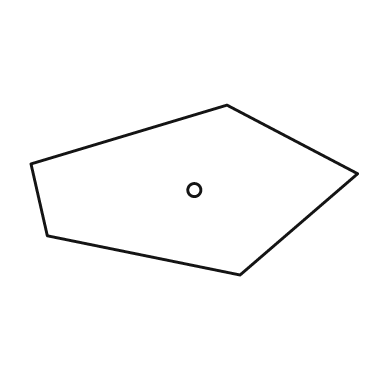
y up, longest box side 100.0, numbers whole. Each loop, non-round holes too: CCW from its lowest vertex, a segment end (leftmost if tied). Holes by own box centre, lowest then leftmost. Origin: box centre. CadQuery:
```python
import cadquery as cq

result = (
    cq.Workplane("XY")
    .moveTo(14.0, -26.0)
    .lineTo(50.0, 5.0)
    .lineTo(10.0, 26.0)
    .lineTo(-50.0, 8.0)
    .lineTo(-45.0, -14.0)
    .close()
    .moveTo(0.0, 0.0)
    .circle(2.0)
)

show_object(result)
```